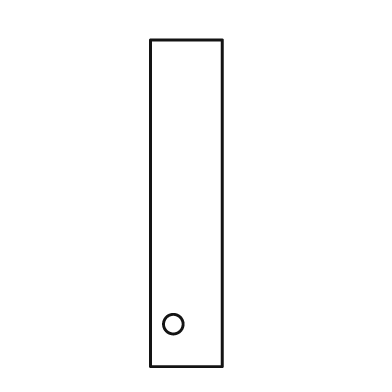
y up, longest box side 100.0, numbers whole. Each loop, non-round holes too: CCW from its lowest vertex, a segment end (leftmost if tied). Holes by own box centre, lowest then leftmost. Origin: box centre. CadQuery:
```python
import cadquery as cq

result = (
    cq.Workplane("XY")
    .moveTo(-11.0, -50.0)
    .lineTo(11.0, -50.0)
    .lineTo(11.0, 50.0)
    .lineTo(-11.0, 50.0)
    .close()
    .moveTo(-4.0, -37.0)
    .circle(3.0)
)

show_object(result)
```